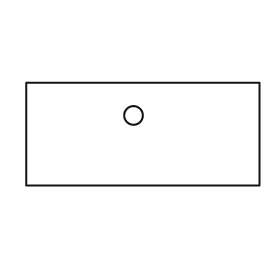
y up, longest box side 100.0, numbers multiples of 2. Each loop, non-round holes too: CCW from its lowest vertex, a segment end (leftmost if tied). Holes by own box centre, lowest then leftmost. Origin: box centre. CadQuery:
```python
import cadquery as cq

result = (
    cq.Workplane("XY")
    .moveTo(-50.0, -22.0)
    .lineTo(50.0, -22.0)
    .lineTo(50.0, 22.0)
    .lineTo(-50.0, 22.0)
    .close()
    .moveTo(-4.0, 8.0)
    .circle(4.0)
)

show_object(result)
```